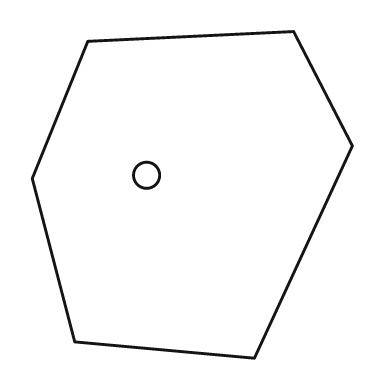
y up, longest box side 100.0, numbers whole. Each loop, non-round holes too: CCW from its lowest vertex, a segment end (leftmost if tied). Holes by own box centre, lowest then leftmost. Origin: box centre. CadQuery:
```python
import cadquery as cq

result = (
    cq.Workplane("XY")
    .moveTo(19.0, -50.0)
    .lineTo(49.0, 15.0)
    .lineTo(31.0, 50.0)
    .lineTo(-32.0, 47.0)
    .lineTo(-49.0, 5.0)
    .lineTo(-36.0, -45.0)
    .close()
    .moveTo(-14.0, 6.0)
    .circle(4.0)
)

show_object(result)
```